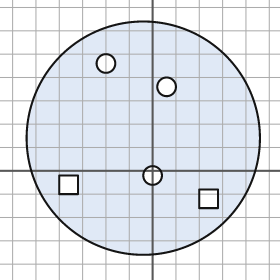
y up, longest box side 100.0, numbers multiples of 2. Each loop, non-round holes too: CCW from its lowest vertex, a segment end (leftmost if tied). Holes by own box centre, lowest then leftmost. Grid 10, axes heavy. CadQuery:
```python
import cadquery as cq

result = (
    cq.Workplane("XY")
    .moveTo(-4.0, 14.0)
    .circle(50.0)
    .moveTo(20.0, -16.0)
    .lineTo(28.0, -16.0)
    .lineTo(28.0, -8.0)
    .lineTo(20.0, -8.0)
    .close()
    .moveTo(-40.0, -10.0)
    .lineTo(-32.0, -10.0)
    .lineTo(-32.0, -2.0)
    .lineTo(-40.0, -2.0)
    .close()
    .moveTo(0.0, -2.0)
    .circle(4.0)
    .moveTo(6.0, 36.0)
    .circle(4.0)
    .moveTo(-20.0, 46.0)
    .circle(4.0)
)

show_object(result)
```